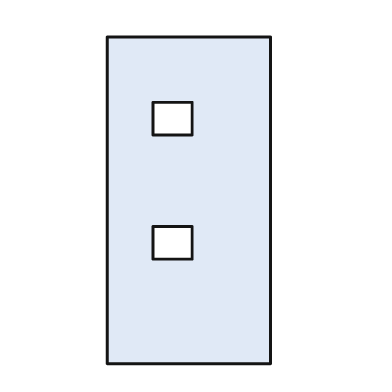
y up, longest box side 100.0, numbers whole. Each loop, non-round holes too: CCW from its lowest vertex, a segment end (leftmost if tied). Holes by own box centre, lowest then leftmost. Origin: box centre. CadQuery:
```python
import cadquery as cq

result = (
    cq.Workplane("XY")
    .moveTo(-25.0, -50.0)
    .lineTo(25.0, -50.0)
    .lineTo(25.0, 50.0)
    .lineTo(-25.0, 50.0)
    .close()
    .moveTo(-11.0, -18.0)
    .lineTo(1.0, -18.0)
    .lineTo(1.0, -8.0)
    .lineTo(-11.0, -8.0)
    .close()
    .moveTo(-11.0, 20.0)
    .lineTo(1.0, 20.0)
    .lineTo(1.0, 30.0)
    .lineTo(-11.0, 30.0)
    .close()
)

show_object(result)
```